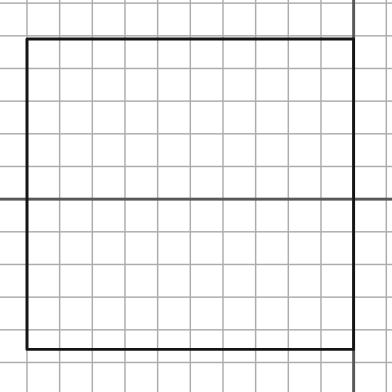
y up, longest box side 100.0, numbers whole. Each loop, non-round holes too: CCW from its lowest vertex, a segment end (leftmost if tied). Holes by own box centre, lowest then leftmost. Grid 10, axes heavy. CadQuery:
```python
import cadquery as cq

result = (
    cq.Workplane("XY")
    .moveTo(-100.0, -46.0)
    .lineTo(0.0, -46.0)
    .lineTo(0.0, 49.0)
    .lineTo(-100.0, 49.0)
    .close()
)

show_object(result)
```